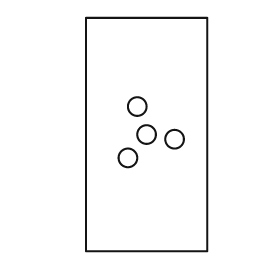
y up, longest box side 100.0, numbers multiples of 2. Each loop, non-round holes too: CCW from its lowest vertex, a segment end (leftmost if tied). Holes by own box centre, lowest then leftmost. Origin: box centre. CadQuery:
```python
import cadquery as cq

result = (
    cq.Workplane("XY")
    .moveTo(-26.0, -50.0)
    .lineTo(26.0, -50.0)
    .lineTo(26.0, 50.0)
    .lineTo(-26.0, 50.0)
    .close()
    .moveTo(-8.0, -10.0)
    .circle(4.0)
    .moveTo(12.0, -2.0)
    .circle(4.0)
    .moveTo(0.0, 0.0)
    .circle(4.0)
    .moveTo(-4.0, 12.0)
    .circle(4.0)
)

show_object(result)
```